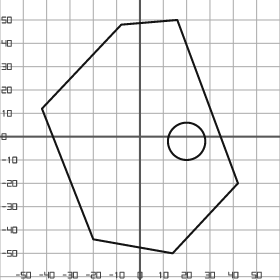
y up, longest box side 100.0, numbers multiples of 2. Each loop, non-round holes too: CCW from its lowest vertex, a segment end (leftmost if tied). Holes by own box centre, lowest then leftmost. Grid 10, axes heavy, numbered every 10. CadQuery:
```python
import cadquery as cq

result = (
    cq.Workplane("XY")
    .moveTo(14.0, -50.0)
    .lineTo(42.0, -20.0)
    .lineTo(16.0, 50.0)
    .lineTo(-8.0, 48.0)
    .lineTo(-42.0, 12.0)
    .lineTo(-20.0, -44.0)
    .close()
    .moveTo(20.0, -2.0)
    .circle(8.0)
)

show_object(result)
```